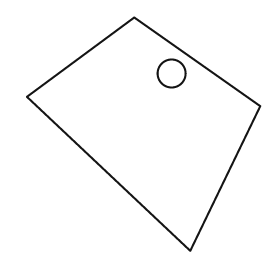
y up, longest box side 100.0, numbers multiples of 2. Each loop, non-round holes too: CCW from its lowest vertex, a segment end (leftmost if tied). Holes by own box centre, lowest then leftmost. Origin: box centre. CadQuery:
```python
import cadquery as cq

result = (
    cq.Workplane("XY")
    .moveTo(20.0, -50.0)
    .lineTo(50.0, 12.0)
    .lineTo(-4.0, 50.0)
    .lineTo(-50.0, 16.0)
    .close()
    .moveTo(12.0, 26.0)
    .circle(6.0)
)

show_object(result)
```